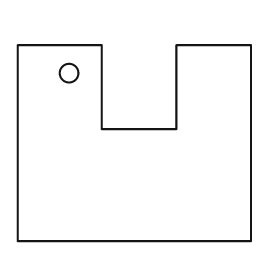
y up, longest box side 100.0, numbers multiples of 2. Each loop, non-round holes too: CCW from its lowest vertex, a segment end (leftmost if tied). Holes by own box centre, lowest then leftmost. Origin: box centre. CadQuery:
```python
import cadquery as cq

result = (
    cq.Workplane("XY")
    .moveTo(-50.0, -42.0)
    .lineTo(50.0, -42.0)
    .lineTo(50.0, 42.0)
    .lineTo(18.0, 42.0)
    .lineTo(18.0, 6.0)
    .lineTo(-14.0, 6.0)
    .lineTo(-14.0, 42.0)
    .lineTo(-50.0, 42.0)
    .close()
    .moveTo(-28.0, 30.0)
    .circle(4.0)
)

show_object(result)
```